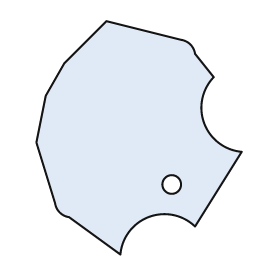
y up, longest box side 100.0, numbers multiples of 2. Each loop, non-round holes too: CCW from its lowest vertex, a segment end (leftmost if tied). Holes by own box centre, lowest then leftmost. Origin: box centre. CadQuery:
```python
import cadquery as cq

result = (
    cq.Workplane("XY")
    .moveTo(-8.0, -50.0)
    .threePointArc((4.0, -34.0), (24.0, -38.0))
    .lineTo(44.0, -6.0)
    .threePointArc((28.0, 6.0), (32.0, 26.0))
    .lineTo(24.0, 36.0)
    .threePointArc((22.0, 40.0), (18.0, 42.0))
    .lineTo(-14.0, 50.0)
    .lineTo(-32.0, 32.0)
    .lineTo(-40.0, 18.0)
    .lineTo(-44.0, -2.0)
    .lineTo(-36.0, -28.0)
    .threePointArc((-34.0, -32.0), (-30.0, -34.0))
    .close()
    .moveTo(14.0, -20.0)
    .circle(4.0)
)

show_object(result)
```